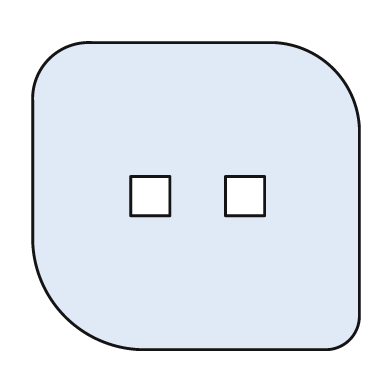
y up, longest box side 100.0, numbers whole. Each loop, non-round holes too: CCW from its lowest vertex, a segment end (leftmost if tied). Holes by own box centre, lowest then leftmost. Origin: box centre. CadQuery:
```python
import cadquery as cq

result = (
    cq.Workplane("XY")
    .moveTo(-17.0, -47.0)
    .lineTo(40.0, -47.0)
    .threePointArc((47.0, -44.0), (50.0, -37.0))
    .lineTo(50.0, 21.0)
    .threePointArc((42.0, 39.0), (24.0, 47.0))
    .lineTo(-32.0, 47.0)
    .threePointArc((-45.0, 42.0), (-50.0, 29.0))
    .lineTo(-50.0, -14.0)
    .threePointArc((-40.0, -37.0), (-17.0, -47.0))
    .close()
    .moveTo(-20.0, -6.0)
    .lineTo(-8.0, -6.0)
    .lineTo(-8.0, 6.0)
    .lineTo(-20.0, 6.0)
    .close()
    .moveTo(9.0, -6.0)
    .lineTo(21.0, -6.0)
    .lineTo(21.0, 6.0)
    .lineTo(9.0, 6.0)
    .close()
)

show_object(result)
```